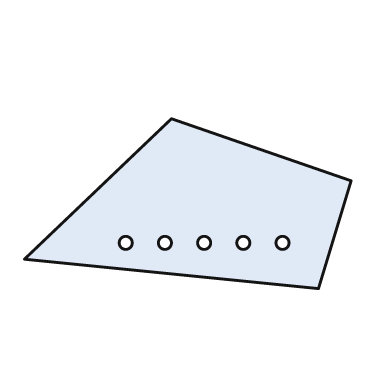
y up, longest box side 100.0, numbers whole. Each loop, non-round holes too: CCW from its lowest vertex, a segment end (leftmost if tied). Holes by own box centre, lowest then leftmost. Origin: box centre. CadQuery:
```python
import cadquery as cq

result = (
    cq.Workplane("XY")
    .moveTo(40.0, -26.0)
    .lineTo(50.0, 7.0)
    .lineTo(-5.0, 26.0)
    .lineTo(-50.0, -17.0)
    .close()
    .moveTo(-19.0, -12.0)
    .circle(2.0)
    .moveTo(-7.0, -12.0)
    .circle(2.0)
    .moveTo(5.0, -12.0)
    .circle(2.0)
    .moveTo(17.0, -12.0)
    .circle(2.0)
    .moveTo(29.0, -12.0)
    .circle(2.0)
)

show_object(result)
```